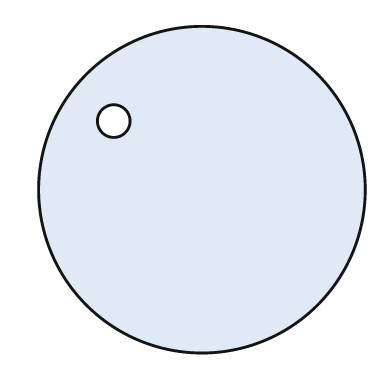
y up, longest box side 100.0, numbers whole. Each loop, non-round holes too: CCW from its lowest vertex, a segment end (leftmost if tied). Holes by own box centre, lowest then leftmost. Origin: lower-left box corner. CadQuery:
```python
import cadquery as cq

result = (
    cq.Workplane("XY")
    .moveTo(50.0, 50.0)
    .circle(50.0)
    .moveTo(23.0, 71.0)
    .circle(5.0)
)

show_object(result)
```